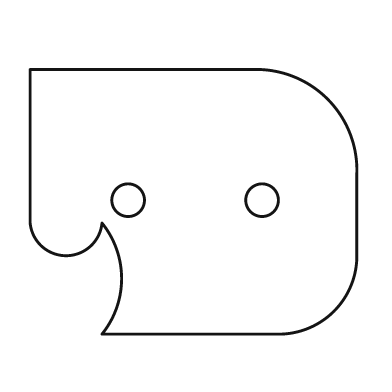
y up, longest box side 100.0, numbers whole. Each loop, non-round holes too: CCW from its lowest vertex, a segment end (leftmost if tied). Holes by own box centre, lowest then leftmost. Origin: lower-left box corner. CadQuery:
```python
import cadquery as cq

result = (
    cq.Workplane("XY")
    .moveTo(22.0, 0.0)
    .lineTo(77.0, 0.0)
    .threePointArc((93.0, 7.0), (100.0, 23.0))
    .lineTo(100.0, 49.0)
    .threePointArc((91.0, 72.0), (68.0, 81.0))
    .lineTo(0.0, 81.0)
    .lineTo(0.0, 34.0)
    .threePointArc((11.0, 24.0), (22.0, 34.0))
    .threePointArc((28.0, 17.0), (22.0, 0.0))
    .close()
    .moveTo(30.0, 41.0)
    .circle(5.0)
    .moveTo(71.0, 41.0)
    .circle(5.0)
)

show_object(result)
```